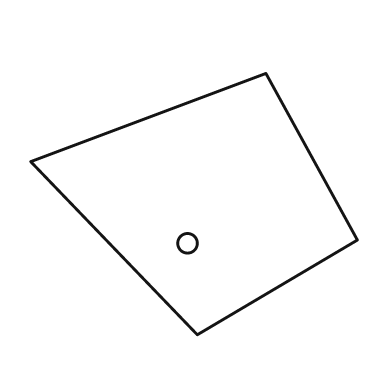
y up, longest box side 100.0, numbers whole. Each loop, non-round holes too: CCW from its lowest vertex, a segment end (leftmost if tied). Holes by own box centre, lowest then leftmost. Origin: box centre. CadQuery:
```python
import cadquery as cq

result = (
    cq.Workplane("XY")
    .moveTo(1.0, -40.0)
    .lineTo(50.0, -11.0)
    .lineTo(22.0, 40.0)
    .lineTo(-50.0, 13.0)
    .close()
    .moveTo(-2.0, -12.0)
    .circle(3.0)
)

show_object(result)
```